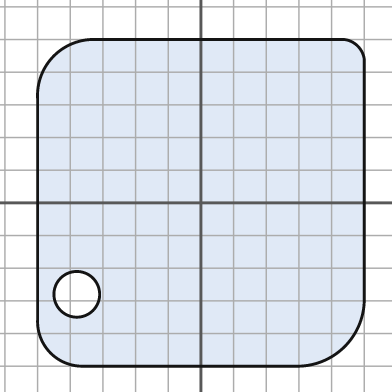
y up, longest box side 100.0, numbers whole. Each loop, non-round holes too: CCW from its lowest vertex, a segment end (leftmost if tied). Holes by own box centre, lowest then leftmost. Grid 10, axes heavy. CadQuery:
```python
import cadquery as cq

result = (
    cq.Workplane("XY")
    .moveTo(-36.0, -50.0)
    .lineTo(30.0, -50.0)
    .threePointArc((44.0, -44.0), (50.0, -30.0))
    .lineTo(50.0, 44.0)
    .threePointArc((48.0, 48.0), (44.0, 50.0))
    .lineTo(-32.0, 50.0)
    .threePointArc((-45.0, 45.0), (-50.0, 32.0))
    .lineTo(-50.0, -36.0)
    .threePointArc((-46.0, -46.0), (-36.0, -50.0))
    .close()
    .moveTo(-38.0, -28.0)
    .circle(7.0)
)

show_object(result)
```